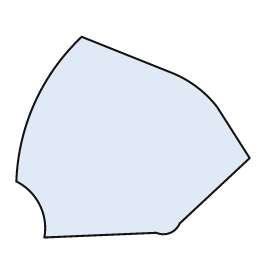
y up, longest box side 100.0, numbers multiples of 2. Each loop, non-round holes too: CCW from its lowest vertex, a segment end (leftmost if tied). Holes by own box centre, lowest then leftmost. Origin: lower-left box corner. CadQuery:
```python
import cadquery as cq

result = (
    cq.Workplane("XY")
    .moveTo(12.0, 0.0)
    .lineTo(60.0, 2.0)
    .threePointArc((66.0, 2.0), (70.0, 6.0))
    .lineTo(100.0, 34.0)
    .lineTo(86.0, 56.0)
    .threePointArc((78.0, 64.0), (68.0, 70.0))
    .lineTo(28.0, 86.0)
    .threePointArc((8.0, 58.0), (0.0, 24.0))
    .threePointArc((10.0, 14.0), (12.0, 0.0))
    .close()
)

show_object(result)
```